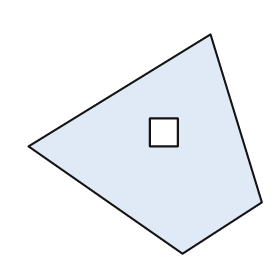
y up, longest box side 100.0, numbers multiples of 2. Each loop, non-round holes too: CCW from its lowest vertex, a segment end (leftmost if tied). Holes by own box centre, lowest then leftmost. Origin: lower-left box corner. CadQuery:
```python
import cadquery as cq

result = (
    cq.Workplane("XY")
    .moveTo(66.0, 0.0)
    .lineTo(100.0, 22.0)
    .lineTo(78.0, 94.0)
    .lineTo(0.0, 46.0)
    .close()
    .moveTo(52.0, 46.0)
    .lineTo(64.0, 46.0)
    .lineTo(64.0, 58.0)
    .lineTo(52.0, 58.0)
    .close()
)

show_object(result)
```